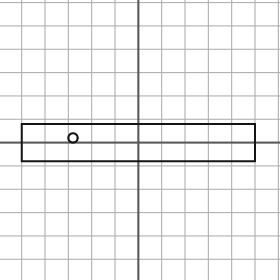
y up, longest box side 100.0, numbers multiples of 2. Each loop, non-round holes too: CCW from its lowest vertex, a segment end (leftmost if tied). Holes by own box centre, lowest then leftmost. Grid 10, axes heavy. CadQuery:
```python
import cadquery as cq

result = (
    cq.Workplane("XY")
    .moveTo(-50.0, -8.0)
    .lineTo(50.0, -8.0)
    .lineTo(50.0, 8.0)
    .lineTo(-50.0, 8.0)
    .close()
    .moveTo(-28.0, 2.0)
    .circle(2.0)
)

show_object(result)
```